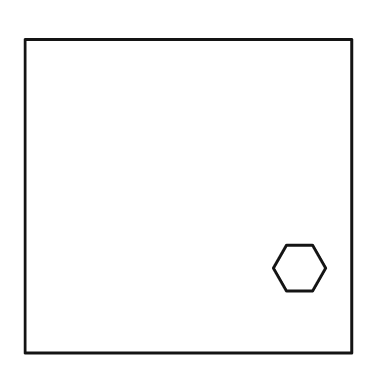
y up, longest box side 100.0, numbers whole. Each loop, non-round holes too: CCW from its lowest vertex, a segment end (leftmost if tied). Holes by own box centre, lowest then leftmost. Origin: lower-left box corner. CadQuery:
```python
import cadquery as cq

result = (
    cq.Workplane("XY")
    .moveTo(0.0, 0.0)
    .lineTo(100.0, 0.0)
    .lineTo(100.0, 96.0)
    .lineTo(0.0, 96.0)
    .close()
    .moveTo(80.0, 19.0)
    .lineTo(88.0, 19.0)
    .lineTo(92.0, 26.0)
    .lineTo(88.0, 33.0)
    .lineTo(80.0, 33.0)
    .lineTo(76.0, 26.0)
    .close()
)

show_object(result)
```